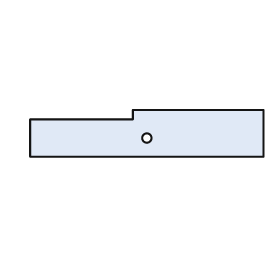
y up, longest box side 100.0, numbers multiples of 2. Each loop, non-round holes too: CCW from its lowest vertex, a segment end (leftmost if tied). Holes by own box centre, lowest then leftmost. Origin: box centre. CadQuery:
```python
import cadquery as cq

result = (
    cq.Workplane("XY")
    .moveTo(-50.0, -10.0)
    .lineTo(50.0, -10.0)
    .lineTo(50.0, 10.0)
    .lineTo(-6.0, 10.0)
    .lineTo(-6.0, 6.0)
    .lineTo(-50.0, 6.0)
    .close()
    .moveTo(0.0, -2.0)
    .circle(2.0)
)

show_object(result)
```